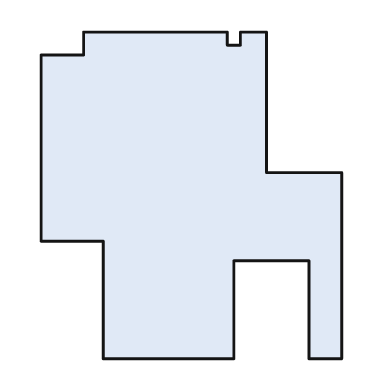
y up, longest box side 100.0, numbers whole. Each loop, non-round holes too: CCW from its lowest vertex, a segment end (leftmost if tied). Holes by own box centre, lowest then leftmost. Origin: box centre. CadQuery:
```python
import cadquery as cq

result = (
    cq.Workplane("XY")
    .moveTo(-27.0, -50.0)
    .lineTo(13.0, -50.0)
    .lineTo(13.0, -20.0)
    .lineTo(36.0, -20.0)
    .lineTo(36.0, -50.0)
    .lineTo(46.0, -50.0)
    .lineTo(46.0, 7.0)
    .lineTo(23.0, 7.0)
    .lineTo(23.0, 50.0)
    .lineTo(15.0, 50.0)
    .lineTo(15.0, 46.0)
    .lineTo(11.0, 46.0)
    .lineTo(11.0, 50.0)
    .lineTo(-33.0, 50.0)
    .lineTo(-33.0, 43.0)
    .lineTo(-46.0, 43.0)
    .lineTo(-46.0, -14.0)
    .lineTo(-27.0, -14.0)
    .close()
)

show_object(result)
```